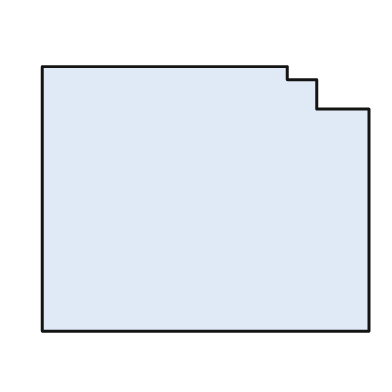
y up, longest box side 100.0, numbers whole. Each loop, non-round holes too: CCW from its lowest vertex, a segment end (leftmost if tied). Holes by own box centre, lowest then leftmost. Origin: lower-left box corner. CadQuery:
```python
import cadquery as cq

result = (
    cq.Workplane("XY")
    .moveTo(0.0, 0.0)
    .lineTo(100.0, 0.0)
    .lineTo(100.0, 68.0)
    .lineTo(84.0, 68.0)
    .lineTo(84.0, 77.0)
    .lineTo(75.0, 77.0)
    .lineTo(75.0, 81.0)
    .lineTo(0.0, 81.0)
    .close()
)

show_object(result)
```